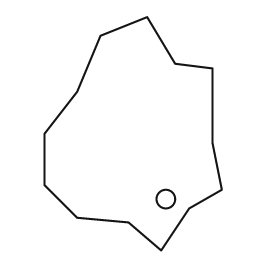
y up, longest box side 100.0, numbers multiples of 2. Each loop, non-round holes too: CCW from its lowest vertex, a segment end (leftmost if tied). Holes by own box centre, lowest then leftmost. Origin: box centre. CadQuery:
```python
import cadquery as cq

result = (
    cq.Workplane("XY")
    .moveTo(12.0, -50.0)
    .lineTo(24.0, -32.0)
    .lineTo(38.0, -24.0)
    .lineTo(34.0, -4.0)
    .lineTo(34.0, 28.0)
    .lineTo(18.0, 30.0)
    .lineTo(6.0, 50.0)
    .lineTo(-14.0, 42.0)
    .lineTo(-24.0, 18.0)
    .lineTo(-38.0, 0.0)
    .lineTo(-38.0, -22.0)
    .lineTo(-24.0, -36.0)
    .lineTo(-2.0, -38.0)
    .close()
    .moveTo(14.0, -28.0)
    .circle(4.0)
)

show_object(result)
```